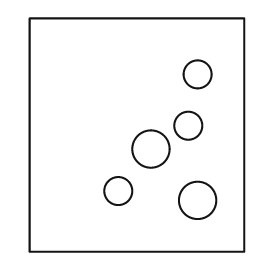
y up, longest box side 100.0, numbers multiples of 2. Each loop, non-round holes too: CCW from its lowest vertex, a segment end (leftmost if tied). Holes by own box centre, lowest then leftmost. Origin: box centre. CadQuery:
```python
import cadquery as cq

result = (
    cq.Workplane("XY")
    .moveTo(-46.0, -50.0)
    .lineTo(46.0, -50.0)
    .lineTo(46.0, 50.0)
    .lineTo(-46.0, 50.0)
    .close()
    .moveTo(26.0, -28.0)
    .circle(8.0)
    .moveTo(-8.0, -24.0)
    .circle(6.0)
    .moveTo(6.0, -6.0)
    .circle(8.0)
    .moveTo(22.0, 4.0)
    .circle(6.0)
    .moveTo(26.0, 26.0)
    .circle(6.0)
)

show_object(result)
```